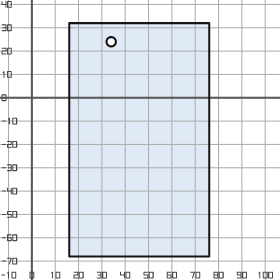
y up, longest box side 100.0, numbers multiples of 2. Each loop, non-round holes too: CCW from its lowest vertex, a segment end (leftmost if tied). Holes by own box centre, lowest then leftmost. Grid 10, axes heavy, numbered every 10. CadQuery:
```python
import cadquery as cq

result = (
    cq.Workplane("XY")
    .moveTo(16.0, -68.0)
    .lineTo(76.0, -68.0)
    .lineTo(76.0, 32.0)
    .lineTo(16.0, 32.0)
    .close()
    .moveTo(34.0, 24.0)
    .circle(2.0)
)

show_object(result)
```